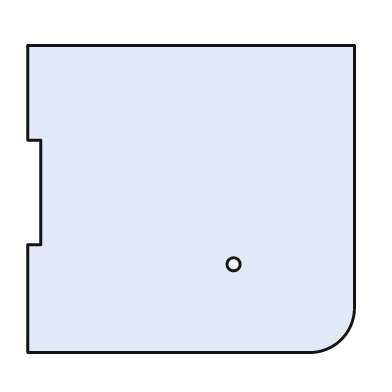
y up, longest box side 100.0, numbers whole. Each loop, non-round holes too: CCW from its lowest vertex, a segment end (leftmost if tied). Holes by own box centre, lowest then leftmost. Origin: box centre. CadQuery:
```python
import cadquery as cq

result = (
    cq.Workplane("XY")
    .moveTo(-50.0, -47.0)
    .lineTo(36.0, -47.0)
    .threePointArc((46.0, -43.0), (50.0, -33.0))
    .lineTo(50.0, 47.0)
    .lineTo(-50.0, 47.0)
    .lineTo(-50.0, 18.0)
    .lineTo(-46.0, 18.0)
    .lineTo(-46.0, -14.0)
    .lineTo(-50.0, -14.0)
    .close()
    .moveTo(13.0, -20.0)
    .circle(2.0)
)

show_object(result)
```